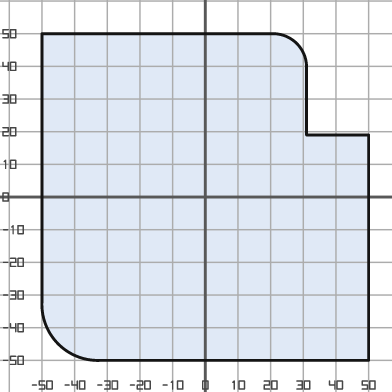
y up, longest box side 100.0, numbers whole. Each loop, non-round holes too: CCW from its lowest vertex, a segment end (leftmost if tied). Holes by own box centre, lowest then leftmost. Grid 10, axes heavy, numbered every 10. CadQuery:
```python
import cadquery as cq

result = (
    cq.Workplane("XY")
    .moveTo(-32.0, -50.0)
    .lineTo(50.0, -50.0)
    .lineTo(50.0, 19.0)
    .lineTo(31.0, 19.0)
    .lineTo(31.0, 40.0)
    .threePointArc((28.0, 47.0), (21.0, 50.0))
    .lineTo(-50.0, 50.0)
    .lineTo(-50.0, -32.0)
    .threePointArc((-45.0, -45.0), (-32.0, -50.0))
    .close()
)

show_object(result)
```